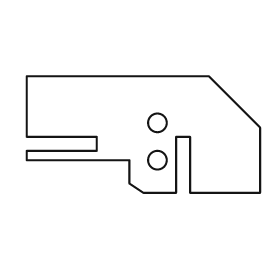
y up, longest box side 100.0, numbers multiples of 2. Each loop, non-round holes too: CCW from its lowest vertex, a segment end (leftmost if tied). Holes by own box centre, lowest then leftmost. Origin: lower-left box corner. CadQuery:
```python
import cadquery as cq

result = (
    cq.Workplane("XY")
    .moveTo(50.0, 0.0)
    .lineTo(64.0, 0.0)
    .lineTo(64.0, 24.0)
    .lineTo(70.0, 24.0)
    .lineTo(70.0, 0.0)
    .lineTo(100.0, 0.0)
    .lineTo(100.0, 28.0)
    .lineTo(78.0, 50.0)
    .lineTo(0.0, 50.0)
    .lineTo(0.0, 24.0)
    .lineTo(30.0, 24.0)
    .lineTo(30.0, 18.0)
    .lineTo(0.0, 18.0)
    .lineTo(0.0, 14.0)
    .lineTo(44.0, 14.0)
    .lineTo(44.0, 4.0)
    .close()
    .moveTo(56.0, 14.0)
    .circle(4.0)
    .moveTo(56.0, 30.0)
    .circle(4.0)
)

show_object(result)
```